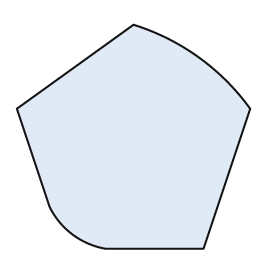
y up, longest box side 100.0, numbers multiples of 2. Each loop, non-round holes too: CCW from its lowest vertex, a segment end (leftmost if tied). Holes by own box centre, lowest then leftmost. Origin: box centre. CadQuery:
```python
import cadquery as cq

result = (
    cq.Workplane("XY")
    .moveTo(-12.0, -48.0)
    .lineTo(30.0, -48.0)
    .lineTo(50.0, 12.0)
    .threePointArc((28.0, 34.0), (0.0, 48.0))
    .lineTo(-50.0, 12.0)
    .lineTo(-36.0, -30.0)
    .threePointArc((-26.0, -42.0), (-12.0, -48.0))
    .close()
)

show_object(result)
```